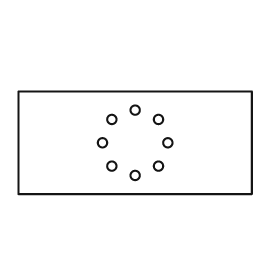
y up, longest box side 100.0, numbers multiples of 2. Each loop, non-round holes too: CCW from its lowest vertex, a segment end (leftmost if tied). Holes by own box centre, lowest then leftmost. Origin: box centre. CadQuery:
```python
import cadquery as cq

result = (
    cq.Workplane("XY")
    .moveTo(-50.0, -22.0)
    .lineTo(50.0, -22.0)
    .lineTo(50.0, 22.0)
    .lineTo(-50.0, 22.0)
    .close()
    .moveTo(0.0, -14.0)
    .circle(2.0)
    .moveTo(-10.0, -10.0)
    .circle(2.0)
    .moveTo(10.0, -10.0)
    .circle(2.0)
    .moveTo(-14.0, 0.0)
    .circle(2.0)
    .moveTo(14.0, 0.0)
    .circle(2.0)
    .moveTo(-10.0, 10.0)
    .circle(2.0)
    .moveTo(10.0, 10.0)
    .circle(2.0)
    .moveTo(0.0, 14.0)
    .circle(2.0)
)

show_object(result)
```